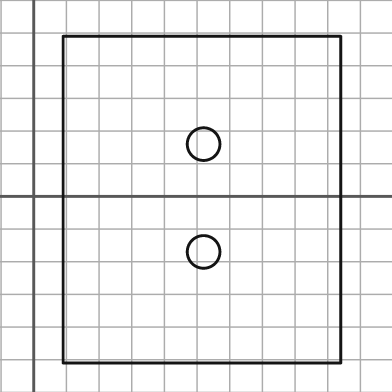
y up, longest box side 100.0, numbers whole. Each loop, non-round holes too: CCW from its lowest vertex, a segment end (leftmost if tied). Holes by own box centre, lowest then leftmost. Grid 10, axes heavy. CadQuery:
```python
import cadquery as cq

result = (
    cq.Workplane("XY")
    .moveTo(9.0, -51.0)
    .lineTo(94.0, -51.0)
    .lineTo(94.0, 49.0)
    .lineTo(9.0, 49.0)
    .close()
    .moveTo(52.0, -17.0)
    .circle(5.0)
    .moveTo(52.0, 16.0)
    .circle(5.0)
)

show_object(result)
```